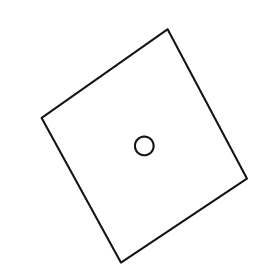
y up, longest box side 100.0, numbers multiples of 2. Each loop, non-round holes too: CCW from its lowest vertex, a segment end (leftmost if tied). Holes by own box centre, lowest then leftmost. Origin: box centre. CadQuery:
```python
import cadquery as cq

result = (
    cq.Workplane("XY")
    .moveTo(-10.0, -50.0)
    .lineTo(44.0, -14.0)
    .lineTo(10.0, 50.0)
    .lineTo(-44.0, 12.0)
    .close()
    .moveTo(0.0, 0.0)
    .circle(4.0)
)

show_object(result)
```